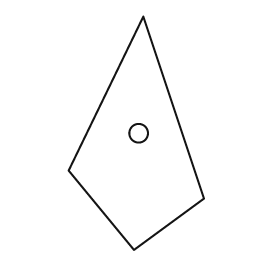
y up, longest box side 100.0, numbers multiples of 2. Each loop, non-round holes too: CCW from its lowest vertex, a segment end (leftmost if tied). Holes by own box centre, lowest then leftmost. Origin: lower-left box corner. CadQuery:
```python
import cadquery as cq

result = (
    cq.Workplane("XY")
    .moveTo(28.0, 0.0)
    .lineTo(58.0, 22.0)
    .lineTo(32.0, 100.0)
    .lineTo(0.0, 34.0)
    .close()
    .moveTo(30.0, 50.0)
    .circle(4.0)
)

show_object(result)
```